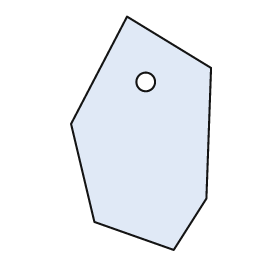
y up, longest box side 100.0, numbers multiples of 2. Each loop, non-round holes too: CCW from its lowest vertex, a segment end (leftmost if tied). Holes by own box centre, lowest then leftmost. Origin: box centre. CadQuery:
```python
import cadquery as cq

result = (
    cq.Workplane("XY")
    .moveTo(14.0, -50.0)
    .lineTo(28.0, -28.0)
    .lineTo(30.0, 28.0)
    .lineTo(-6.0, 50.0)
    .lineTo(-30.0, 4.0)
    .lineTo(-20.0, -38.0)
    .close()
    .moveTo(2.0, 22.0)
    .circle(4.0)
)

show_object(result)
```